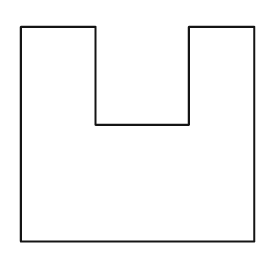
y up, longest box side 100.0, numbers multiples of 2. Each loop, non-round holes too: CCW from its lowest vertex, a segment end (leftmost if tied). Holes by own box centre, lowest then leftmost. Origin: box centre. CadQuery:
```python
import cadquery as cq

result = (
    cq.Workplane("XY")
    .moveTo(-50.0, -46.0)
    .lineTo(50.0, -46.0)
    .lineTo(50.0, 46.0)
    .lineTo(22.0, 46.0)
    .lineTo(22.0, 4.0)
    .lineTo(-18.0, 4.0)
    .lineTo(-18.0, 46.0)
    .lineTo(-50.0, 46.0)
    .close()
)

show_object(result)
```